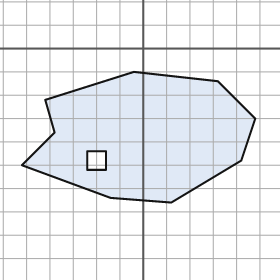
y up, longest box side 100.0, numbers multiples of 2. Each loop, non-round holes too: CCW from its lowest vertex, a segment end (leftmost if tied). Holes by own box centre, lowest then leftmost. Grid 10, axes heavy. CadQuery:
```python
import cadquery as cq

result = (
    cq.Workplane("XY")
    .moveTo(12.0, -66.0)
    .lineTo(42.0, -48.0)
    .lineTo(48.0, -30.0)
    .lineTo(32.0, -14.0)
    .lineTo(-4.0, -10.0)
    .lineTo(-42.0, -22.0)
    .lineTo(-38.0, -36.0)
    .lineTo(-52.0, -50.0)
    .lineTo(-14.0, -64.0)
    .close()
    .moveTo(-24.0, -52.0)
    .lineTo(-16.0, -52.0)
    .lineTo(-16.0, -44.0)
    .lineTo(-24.0, -44.0)
    .close()
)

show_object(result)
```